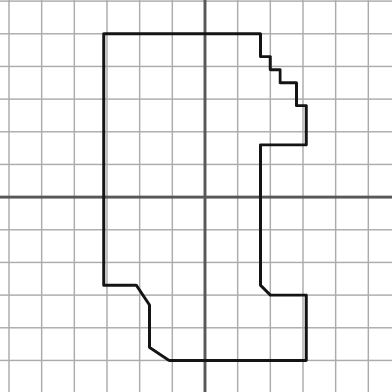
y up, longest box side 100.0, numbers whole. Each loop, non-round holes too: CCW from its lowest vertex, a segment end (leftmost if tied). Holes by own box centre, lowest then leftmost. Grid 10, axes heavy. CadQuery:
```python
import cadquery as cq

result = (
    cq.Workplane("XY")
    .moveTo(-11.0, -50.0)
    .lineTo(31.0, -50.0)
    .lineTo(31.0, -30.0)
    .lineTo(20.0, -30.0)
    .lineTo(17.0, -27.0)
    .lineTo(17.0, 16.0)
    .lineTo(31.0, 16.0)
    .lineTo(31.0, 28.0)
    .lineTo(28.0, 28.0)
    .lineTo(28.0, 35.0)
    .lineTo(23.0, 35.0)
    .lineTo(23.0, 39.0)
    .lineTo(20.0, 39.0)
    .lineTo(20.0, 43.0)
    .lineTo(17.0, 43.0)
    .lineTo(17.0, 50.0)
    .lineTo(-31.0, 50.0)
    .lineTo(-31.0, -27.0)
    .lineTo(-21.0, -27.0)
    .lineTo(-17.0, -33.0)
    .lineTo(-17.0, -46.0)
    .close()
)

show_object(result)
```